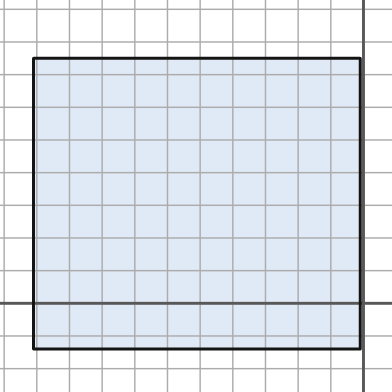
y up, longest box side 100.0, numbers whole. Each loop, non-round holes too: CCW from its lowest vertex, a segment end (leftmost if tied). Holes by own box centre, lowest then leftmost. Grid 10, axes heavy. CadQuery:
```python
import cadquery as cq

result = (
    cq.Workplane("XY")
    .moveTo(-101.0, -14.0)
    .lineTo(-1.0, -14.0)
    .lineTo(-1.0, 75.0)
    .lineTo(-101.0, 75.0)
    .close()
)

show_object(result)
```